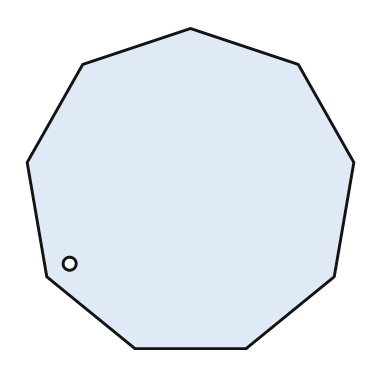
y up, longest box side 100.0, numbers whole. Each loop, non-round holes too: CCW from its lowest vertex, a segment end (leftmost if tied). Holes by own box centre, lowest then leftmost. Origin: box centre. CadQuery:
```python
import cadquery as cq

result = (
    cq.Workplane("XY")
    .moveTo(-17.0, -49.0)
    .lineTo(17.0, -49.0)
    .lineTo(44.0, -27.0)
    .lineTo(50.0, 8.0)
    .lineTo(33.0, 38.0)
    .lineTo(0.0, 49.0)
    .lineTo(-33.0, 38.0)
    .lineTo(-50.0, 8.0)
    .lineTo(-44.0, -27.0)
    .close()
    .moveTo(-37.0, -23.0)
    .circle(2.0)
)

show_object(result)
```